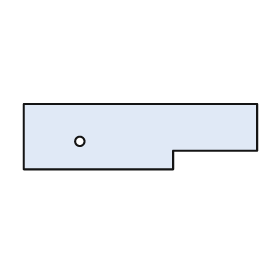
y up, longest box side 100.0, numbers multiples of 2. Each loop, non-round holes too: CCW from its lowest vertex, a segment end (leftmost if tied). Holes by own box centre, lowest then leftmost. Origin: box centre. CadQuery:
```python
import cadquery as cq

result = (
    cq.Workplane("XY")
    .moveTo(-50.0, -14.0)
    .lineTo(14.0, -14.0)
    .lineTo(14.0, -6.0)
    .lineTo(50.0, -6.0)
    .lineTo(50.0, 14.0)
    .lineTo(-50.0, 14.0)
    .close()
    .moveTo(-26.0, -2.0)
    .circle(2.0)
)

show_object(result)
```